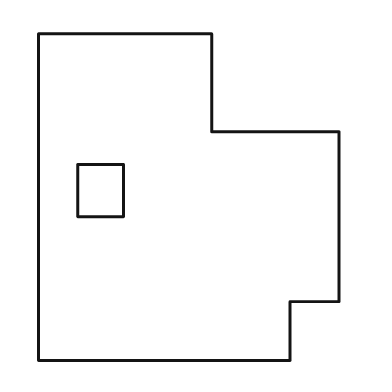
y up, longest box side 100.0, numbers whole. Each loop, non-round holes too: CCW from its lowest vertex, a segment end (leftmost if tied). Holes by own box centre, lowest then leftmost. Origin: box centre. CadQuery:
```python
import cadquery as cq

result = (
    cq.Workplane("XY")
    .moveTo(-46.0, -50.0)
    .lineTo(31.0, -50.0)
    .lineTo(31.0, -32.0)
    .lineTo(46.0, -32.0)
    .lineTo(46.0, 20.0)
    .lineTo(7.0, 20.0)
    .lineTo(7.0, 50.0)
    .lineTo(-46.0, 50.0)
    .close()
    .moveTo(-34.0, -6.0)
    .lineTo(-20.0, -6.0)
    .lineTo(-20.0, 10.0)
    .lineTo(-34.0, 10.0)
    .close()
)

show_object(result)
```